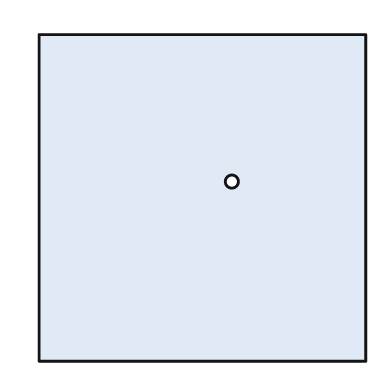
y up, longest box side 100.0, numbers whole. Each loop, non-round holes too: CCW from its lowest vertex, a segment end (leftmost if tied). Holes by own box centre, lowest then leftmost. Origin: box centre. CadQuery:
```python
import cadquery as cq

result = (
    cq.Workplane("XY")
    .moveTo(-50.0, -50.0)
    .lineTo(50.0, -50.0)
    .lineTo(50.0, 50.0)
    .lineTo(-50.0, 50.0)
    .close()
    .moveTo(9.0, 5.0)
    .circle(2.0)
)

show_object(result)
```